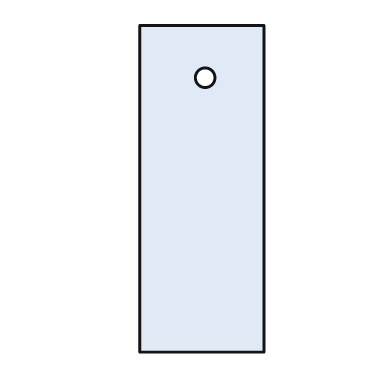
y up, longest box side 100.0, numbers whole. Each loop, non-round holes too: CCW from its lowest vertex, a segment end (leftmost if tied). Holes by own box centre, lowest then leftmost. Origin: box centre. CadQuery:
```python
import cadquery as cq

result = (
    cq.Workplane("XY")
    .moveTo(-19.0, -50.0)
    .lineTo(19.0, -50.0)
    .lineTo(19.0, 50.0)
    .lineTo(-19.0, 50.0)
    .close()
    .moveTo(1.0, 34.0)
    .circle(3.0)
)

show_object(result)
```